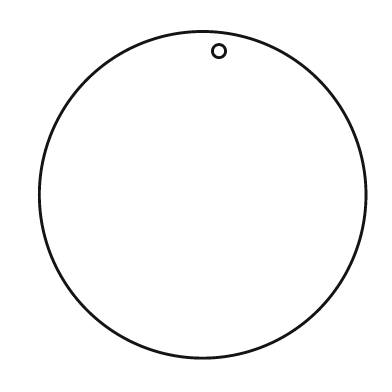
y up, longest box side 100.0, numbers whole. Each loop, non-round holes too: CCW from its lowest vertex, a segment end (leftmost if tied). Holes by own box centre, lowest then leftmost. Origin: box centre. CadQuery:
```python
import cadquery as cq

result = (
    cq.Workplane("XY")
    .moveTo(0.0, 0.0)
    .circle(50.0)
    .moveTo(5.0, 44.0)
    .circle(2.0)
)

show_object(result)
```